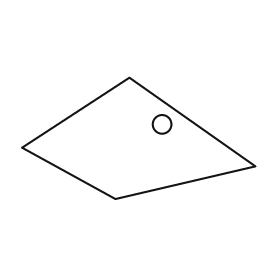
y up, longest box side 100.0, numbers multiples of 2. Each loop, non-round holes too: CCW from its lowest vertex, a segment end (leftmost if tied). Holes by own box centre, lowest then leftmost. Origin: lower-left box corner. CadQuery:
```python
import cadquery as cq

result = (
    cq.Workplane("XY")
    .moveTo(40.0, 0.0)
    .lineTo(100.0, 14.0)
    .lineTo(46.0, 52.0)
    .lineTo(0.0, 22.0)
    .close()
    .moveTo(60.0, 32.0)
    .circle(4.0)
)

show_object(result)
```